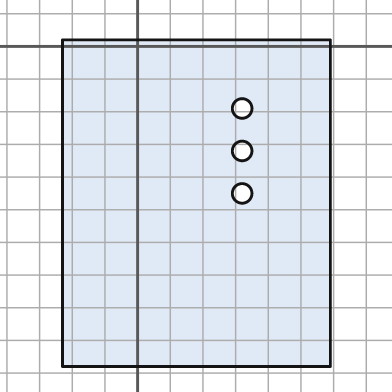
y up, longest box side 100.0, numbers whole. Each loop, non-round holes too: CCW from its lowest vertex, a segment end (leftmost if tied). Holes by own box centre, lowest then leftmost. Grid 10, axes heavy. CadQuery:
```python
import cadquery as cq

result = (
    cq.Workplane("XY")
    .moveTo(-23.0, -98.0)
    .lineTo(59.0, -98.0)
    .lineTo(59.0, 2.0)
    .lineTo(-23.0, 2.0)
    .close()
    .moveTo(32.0, -45.0)
    .circle(3.0)
    .moveTo(32.0, -32.0)
    .circle(3.0)
    .moveTo(32.0, -19.0)
    .circle(3.0)
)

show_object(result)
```